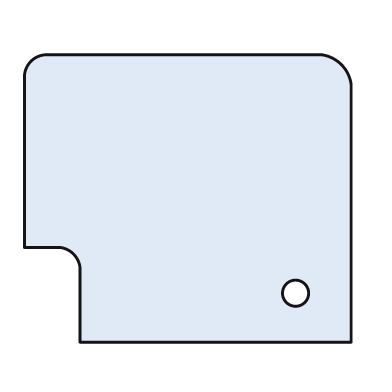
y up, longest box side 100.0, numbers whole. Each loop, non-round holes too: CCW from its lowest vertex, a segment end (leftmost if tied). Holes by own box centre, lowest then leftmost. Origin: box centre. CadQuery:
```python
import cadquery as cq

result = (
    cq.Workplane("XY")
    .moveTo(-33.0, -44.0)
    .lineTo(50.0, -44.0)
    .lineTo(50.0, 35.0)
    .threePointArc((47.0, 41.0), (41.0, 44.0))
    .lineTo(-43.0, 44.0)
    .threePointArc((-48.0, 42.0), (-50.0, 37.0))
    .lineTo(-50.0, -15.0)
    .lineTo(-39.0, -15.0)
    .threePointArc((-35.0, -17.0), (-33.0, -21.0))
    .close()
    .moveTo(33.0, -29.0)
    .circle(4.0)
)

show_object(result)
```